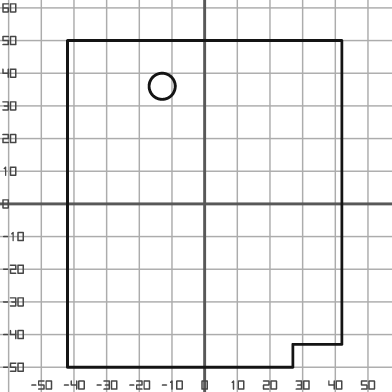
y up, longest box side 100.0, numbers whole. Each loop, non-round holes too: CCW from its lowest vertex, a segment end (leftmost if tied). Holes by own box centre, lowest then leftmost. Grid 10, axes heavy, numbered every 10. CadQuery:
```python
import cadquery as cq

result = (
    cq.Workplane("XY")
    .moveTo(-42.0, -50.0)
    .lineTo(27.0, -50.0)
    .lineTo(27.0, -43.0)
    .lineTo(42.0, -43.0)
    .lineTo(42.0, 50.0)
    .lineTo(-42.0, 50.0)
    .close()
    .moveTo(-13.0, 36.0)
    .circle(4.0)
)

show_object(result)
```